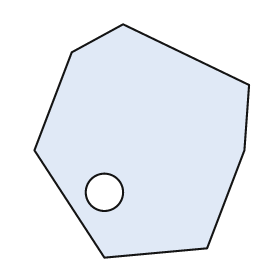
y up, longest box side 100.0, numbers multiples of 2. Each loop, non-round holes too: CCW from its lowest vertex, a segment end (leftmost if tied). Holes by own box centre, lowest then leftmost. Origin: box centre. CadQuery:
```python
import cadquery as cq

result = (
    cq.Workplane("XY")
    .moveTo(-16.0, -50.0)
    .lineTo(28.0, -46.0)
    .lineTo(44.0, -4.0)
    .lineTo(46.0, 24.0)
    .lineTo(-8.0, 50.0)
    .lineTo(-30.0, 38.0)
    .lineTo(-46.0, -4.0)
    .close()
    .moveTo(-16.0, -22.0)
    .circle(8.0)
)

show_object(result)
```